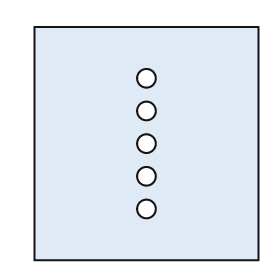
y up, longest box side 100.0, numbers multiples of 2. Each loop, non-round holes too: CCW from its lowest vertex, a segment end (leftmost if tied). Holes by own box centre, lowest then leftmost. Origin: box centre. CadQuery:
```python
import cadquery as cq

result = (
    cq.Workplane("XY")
    .moveTo(-48.0, -50.0)
    .lineTo(48.0, -50.0)
    .lineTo(48.0, 50.0)
    .lineTo(-48.0, 50.0)
    .close()
    .moveTo(0.0, -28.0)
    .circle(4.0)
    .moveTo(0.0, -14.0)
    .circle(4.0)
    .moveTo(0.0, 0.0)
    .circle(4.0)
    .moveTo(0.0, 14.0)
    .circle(4.0)
    .moveTo(0.0, 28.0)
    .circle(4.0)
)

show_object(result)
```